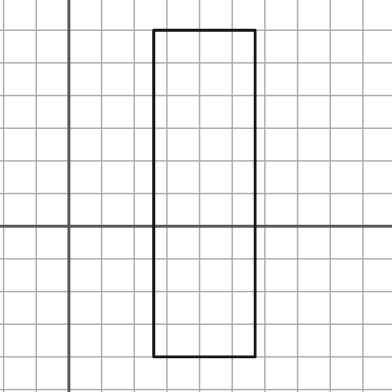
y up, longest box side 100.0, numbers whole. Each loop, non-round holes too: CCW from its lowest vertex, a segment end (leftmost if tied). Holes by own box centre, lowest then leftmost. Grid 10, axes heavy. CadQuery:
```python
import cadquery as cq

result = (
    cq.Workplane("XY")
    .moveTo(26.0, -40.0)
    .lineTo(57.0, -40.0)
    .lineTo(57.0, 60.0)
    .lineTo(26.0, 60.0)
    .close()
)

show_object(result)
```